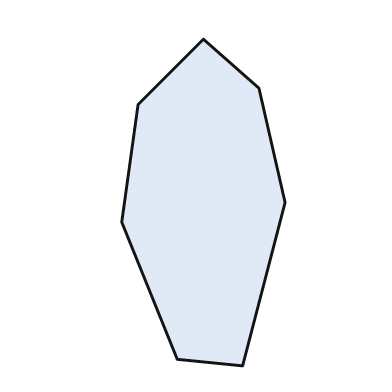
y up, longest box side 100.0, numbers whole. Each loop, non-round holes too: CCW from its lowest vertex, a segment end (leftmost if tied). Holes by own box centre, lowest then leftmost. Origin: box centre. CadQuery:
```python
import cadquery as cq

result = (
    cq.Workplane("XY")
    .moveTo(12.0, -50.0)
    .lineTo(25.0, 0.0)
    .lineTo(17.0, 35.0)
    .lineTo(0.0, 50.0)
    .lineTo(-20.0, 30.0)
    .lineTo(-25.0, -6.0)
    .lineTo(-8.0, -48.0)
    .close()
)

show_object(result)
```